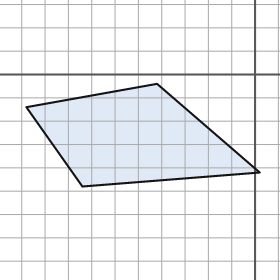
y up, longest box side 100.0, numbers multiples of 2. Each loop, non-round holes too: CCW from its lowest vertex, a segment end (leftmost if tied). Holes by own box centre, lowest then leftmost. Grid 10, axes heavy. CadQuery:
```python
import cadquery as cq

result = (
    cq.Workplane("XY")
    .moveTo(-74.0, -48.0)
    .lineTo(2.0, -42.0)
    .lineTo(-42.0, -4.0)
    .lineTo(-98.0, -14.0)
    .close()
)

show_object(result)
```